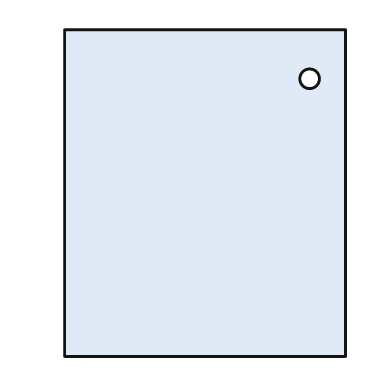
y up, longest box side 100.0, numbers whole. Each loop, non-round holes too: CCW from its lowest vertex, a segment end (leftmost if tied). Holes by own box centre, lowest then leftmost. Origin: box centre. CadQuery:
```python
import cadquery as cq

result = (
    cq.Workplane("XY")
    .moveTo(-43.0, -50.0)
    .lineTo(43.0, -50.0)
    .lineTo(43.0, 50.0)
    .lineTo(-43.0, 50.0)
    .close()
    .moveTo(32.0, 35.0)
    .circle(3.0)
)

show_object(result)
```